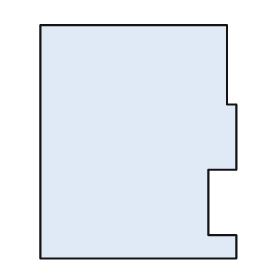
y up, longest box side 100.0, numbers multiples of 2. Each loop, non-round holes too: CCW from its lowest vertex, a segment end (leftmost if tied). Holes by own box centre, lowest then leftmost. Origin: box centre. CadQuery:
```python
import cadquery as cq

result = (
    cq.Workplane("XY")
    .moveTo(-42.0, -50.0)
    .lineTo(42.0, -50.0)
    .lineTo(42.0, -40.0)
    .lineTo(30.0, -40.0)
    .lineTo(30.0, -12.0)
    .lineTo(42.0, -12.0)
    .lineTo(42.0, 16.0)
    .lineTo(38.0, 16.0)
    .lineTo(38.0, 50.0)
    .lineTo(-42.0, 50.0)
    .close()
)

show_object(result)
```